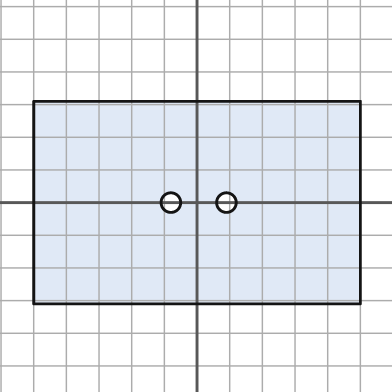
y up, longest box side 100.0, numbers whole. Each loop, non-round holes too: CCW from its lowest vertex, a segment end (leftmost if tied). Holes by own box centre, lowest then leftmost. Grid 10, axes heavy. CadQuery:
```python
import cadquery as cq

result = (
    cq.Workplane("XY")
    .moveTo(-50.0, -31.0)
    .lineTo(50.0, -31.0)
    .lineTo(50.0, 31.0)
    .lineTo(-50.0, 31.0)
    .close()
    .moveTo(-8.0, 0.0)
    .circle(3.0)
    .moveTo(9.0, 0.0)
    .circle(3.0)
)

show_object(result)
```